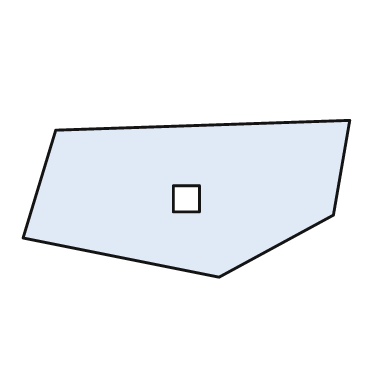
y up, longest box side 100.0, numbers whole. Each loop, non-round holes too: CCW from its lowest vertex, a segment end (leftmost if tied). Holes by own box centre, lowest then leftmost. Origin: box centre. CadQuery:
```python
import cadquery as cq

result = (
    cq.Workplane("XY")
    .moveTo(10.0, -24.0)
    .lineTo(45.0, -5.0)
    .lineTo(50.0, 24.0)
    .lineTo(-40.0, 21.0)
    .lineTo(-50.0, -12.0)
    .close()
    .moveTo(-4.0, -4.0)
    .lineTo(4.0, -4.0)
    .lineTo(4.0, 4.0)
    .lineTo(-4.0, 4.0)
    .close()
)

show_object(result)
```